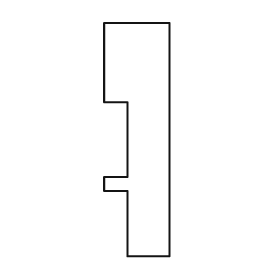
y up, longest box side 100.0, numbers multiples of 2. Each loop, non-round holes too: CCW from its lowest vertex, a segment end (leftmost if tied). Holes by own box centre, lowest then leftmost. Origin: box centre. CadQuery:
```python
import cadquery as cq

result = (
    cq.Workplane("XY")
    .moveTo(-4.0, -50.0)
    .lineTo(14.0, -50.0)
    .lineTo(14.0, 50.0)
    .lineTo(-14.0, 50.0)
    .lineTo(-14.0, 16.0)
    .lineTo(-4.0, 16.0)
    .lineTo(-4.0, -16.0)
    .lineTo(-14.0, -16.0)
    .lineTo(-14.0, -22.0)
    .lineTo(-4.0, -22.0)
    .close()
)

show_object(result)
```